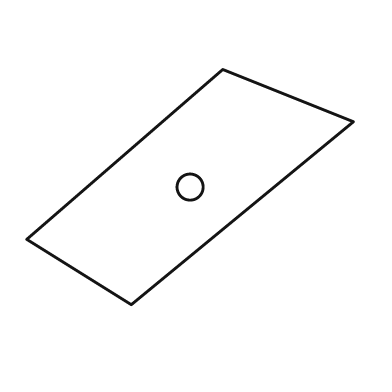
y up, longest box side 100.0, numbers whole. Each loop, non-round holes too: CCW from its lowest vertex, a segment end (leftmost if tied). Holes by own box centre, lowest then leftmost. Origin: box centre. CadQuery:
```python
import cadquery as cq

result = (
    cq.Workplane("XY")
    .moveTo(-18.0, -36.0)
    .lineTo(50.0, 20.0)
    .lineTo(10.0, 36.0)
    .lineTo(-50.0, -16.0)
    .close()
    .moveTo(0.0, 0.0)
    .circle(4.0)
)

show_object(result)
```